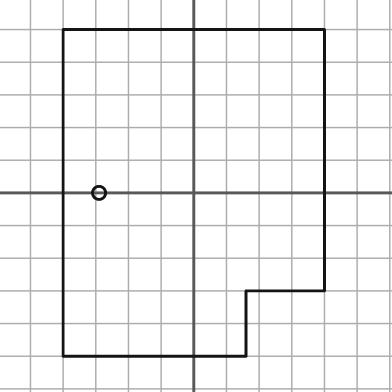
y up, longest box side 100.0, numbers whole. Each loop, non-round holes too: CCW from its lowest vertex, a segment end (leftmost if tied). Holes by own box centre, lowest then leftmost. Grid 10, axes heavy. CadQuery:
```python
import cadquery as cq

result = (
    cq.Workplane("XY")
    .moveTo(-40.0, -50.0)
    .lineTo(16.0, -50.0)
    .lineTo(16.0, -30.0)
    .lineTo(40.0, -30.0)
    .lineTo(40.0, 50.0)
    .lineTo(-40.0, 50.0)
    .close()
    .moveTo(-29.0, 0.0)
    .circle(2.0)
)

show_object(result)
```